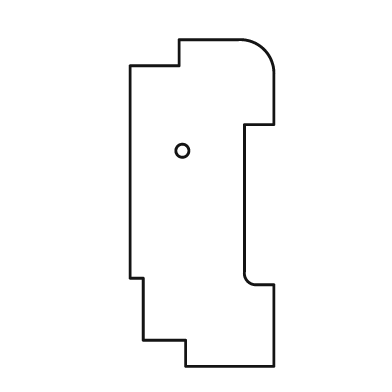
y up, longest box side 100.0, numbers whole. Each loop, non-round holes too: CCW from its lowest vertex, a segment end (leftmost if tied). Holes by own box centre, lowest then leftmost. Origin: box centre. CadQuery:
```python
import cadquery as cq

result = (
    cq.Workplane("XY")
    .moveTo(-5.0, -50.0)
    .lineTo(22.0, -50.0)
    .lineTo(22.0, -25.0)
    .lineTo(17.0, -25.0)
    .threePointArc((14.0, -24.0), (13.0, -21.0))
    .lineTo(13.0, 24.0)
    .lineTo(22.0, 24.0)
    .lineTo(22.0, 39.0)
    .threePointArc((19.0, 47.0), (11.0, 50.0))
    .lineTo(-7.0, 50.0)
    .lineTo(-7.0, 42.0)
    .lineTo(-22.0, 42.0)
    .lineTo(-22.0, -23.0)
    .lineTo(-18.0, -23.0)
    .lineTo(-18.0, -42.0)
    .lineTo(-5.0, -42.0)
    .close()
    .moveTo(-6.0, 16.0)
    .circle(2.0)
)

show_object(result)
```